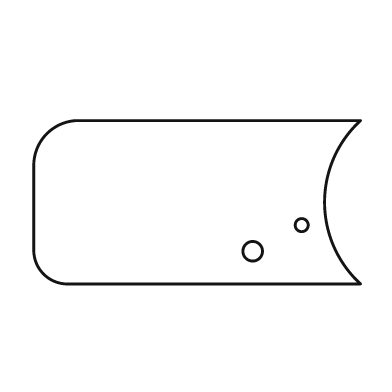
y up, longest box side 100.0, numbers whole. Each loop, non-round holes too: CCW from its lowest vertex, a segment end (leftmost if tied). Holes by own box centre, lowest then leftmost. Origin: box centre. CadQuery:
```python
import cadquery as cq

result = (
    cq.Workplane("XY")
    .moveTo(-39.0, -25.0)
    .lineTo(50.0, -25.0)
    .threePointArc((39.0, 0.0), (50.0, 25.0))
    .lineTo(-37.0, 25.0)
    .threePointArc((-46.0, 21.0), (-50.0, 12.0))
    .lineTo(-50.0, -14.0)
    .threePointArc((-47.0, -22.0), (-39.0, -25.0))
    .close()
    .moveTo(17.0, -15.0)
    .circle(3.0)
    .moveTo(32.0, -7.0)
    .circle(2.0)
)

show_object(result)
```